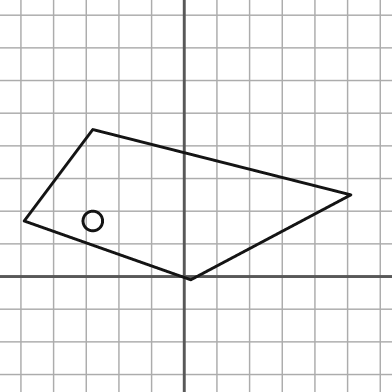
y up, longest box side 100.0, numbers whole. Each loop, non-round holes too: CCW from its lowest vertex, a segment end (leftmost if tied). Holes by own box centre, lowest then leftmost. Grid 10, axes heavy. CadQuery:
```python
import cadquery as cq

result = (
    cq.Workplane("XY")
    .moveTo(2.0, -1.0)
    .lineTo(51.0, 25.0)
    .lineTo(-28.0, 45.0)
    .lineTo(-49.0, 17.0)
    .close()
    .moveTo(-28.0, 17.0)
    .circle(3.0)
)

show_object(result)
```